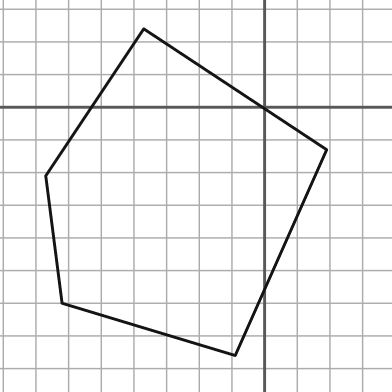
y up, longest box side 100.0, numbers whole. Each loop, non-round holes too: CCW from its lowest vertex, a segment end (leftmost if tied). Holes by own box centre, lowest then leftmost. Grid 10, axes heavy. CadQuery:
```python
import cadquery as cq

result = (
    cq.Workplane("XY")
    .moveTo(-9.0, -76.0)
    .lineTo(19.0, -13.0)
    .lineTo(-37.0, 24.0)
    .lineTo(-67.0, -21.0)
    .lineTo(-62.0, -60.0)
    .close()
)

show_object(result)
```